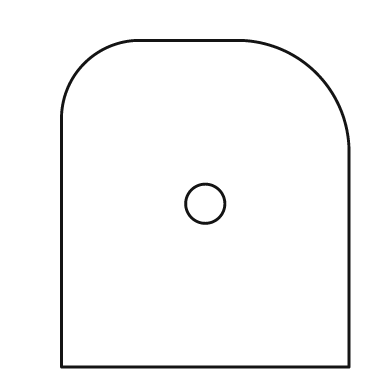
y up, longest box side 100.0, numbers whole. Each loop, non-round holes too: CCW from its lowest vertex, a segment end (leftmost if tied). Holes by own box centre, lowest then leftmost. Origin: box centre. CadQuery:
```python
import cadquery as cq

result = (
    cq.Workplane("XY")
    .moveTo(-44.0, -50.0)
    .lineTo(44.0, -50.0)
    .lineTo(44.0, 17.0)
    .threePointArc((34.0, 40.0), (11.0, 50.0))
    .lineTo(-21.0, 50.0)
    .threePointArc((-37.0, 43.0), (-44.0, 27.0))
    .close()
    .moveTo(0.0, 0.0)
    .circle(6.0)
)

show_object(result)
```